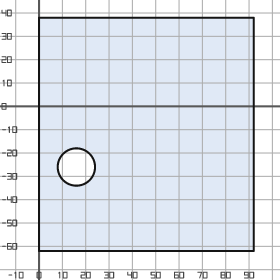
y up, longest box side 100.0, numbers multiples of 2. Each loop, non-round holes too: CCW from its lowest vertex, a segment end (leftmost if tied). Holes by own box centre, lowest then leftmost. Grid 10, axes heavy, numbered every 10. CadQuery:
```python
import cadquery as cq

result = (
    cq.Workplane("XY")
    .moveTo(0.0, -62.0)
    .lineTo(92.0, -62.0)
    .lineTo(92.0, 38.0)
    .lineTo(0.0, 38.0)
    .close()
    .moveTo(16.0, -26.0)
    .circle(8.0)
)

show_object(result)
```